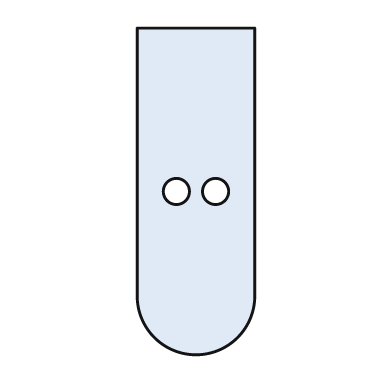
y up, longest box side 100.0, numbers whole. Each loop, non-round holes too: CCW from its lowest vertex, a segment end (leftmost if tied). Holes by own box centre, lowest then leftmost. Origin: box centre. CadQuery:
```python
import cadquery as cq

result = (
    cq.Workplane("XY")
    .moveTo(-18.0, -32.0)
    .threePointArc((0.0, -50.0), (18.0, -32.0))
    .lineTo(18.0, 50.0)
    .lineTo(-18.0, 50.0)
    .close()
    .moveTo(-6.0, 0.0)
    .circle(4.0)
    .moveTo(6.0, 0.0)
    .circle(4.0)
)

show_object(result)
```